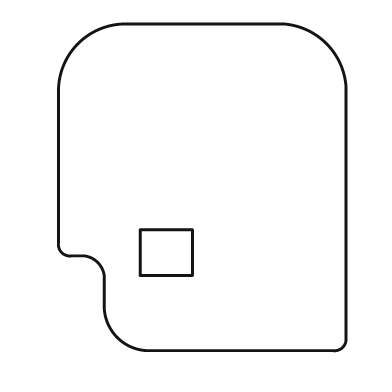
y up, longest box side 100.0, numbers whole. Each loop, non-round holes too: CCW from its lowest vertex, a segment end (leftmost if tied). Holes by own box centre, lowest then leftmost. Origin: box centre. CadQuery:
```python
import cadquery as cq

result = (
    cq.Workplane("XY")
    .moveTo(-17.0, -50.0)
    .lineTo(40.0, -50.0)
    .threePointArc((43.0, -49.0), (44.0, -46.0))
    .lineTo(44.0, 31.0)
    .threePointArc((38.0, 44.0), (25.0, 50.0))
    .lineTo(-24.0, 50.0)
    .threePointArc((-38.0, 44.0), (-44.0, 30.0))
    .lineTo(-44.0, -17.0)
    .threePointArc((-43.0, -20.0), (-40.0, -21.0))
    .lineTo(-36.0, -21.0)
    .threePointArc((-32.0, -23.0), (-30.0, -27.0))
    .lineTo(-30.0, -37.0)
    .threePointArc((-26.0, -46.0), (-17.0, -50.0))
    .close()
    .moveTo(-19.0, -27.0)
    .lineTo(-3.0, -27.0)
    .lineTo(-3.0, -13.0)
    .lineTo(-19.0, -13.0)
    .close()
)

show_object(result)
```